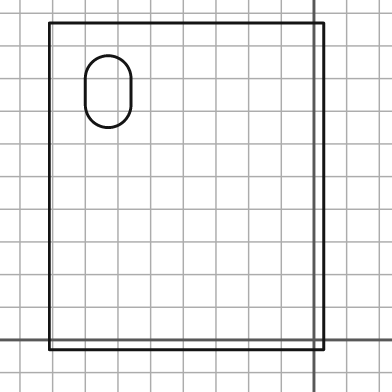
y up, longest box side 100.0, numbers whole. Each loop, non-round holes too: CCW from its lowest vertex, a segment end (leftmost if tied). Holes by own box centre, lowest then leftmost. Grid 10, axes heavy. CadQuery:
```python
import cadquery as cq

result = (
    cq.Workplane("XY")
    .moveTo(-81.0, -3.0)
    .lineTo(3.0, -3.0)
    .lineTo(3.0, 97.0)
    .lineTo(-81.0, 97.0)
    .close()
    .moveTo(-70.0, 72.0)
    .threePointArc((-63.0, 65.0), (-56.0, 72.0))
    .lineTo(-56.0, 80.0)
    .threePointArc((-63.0, 87.0), (-70.0, 80.0))
    .close()
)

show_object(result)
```